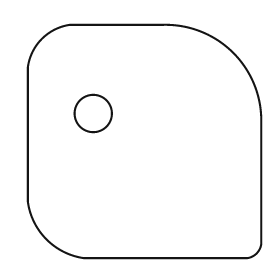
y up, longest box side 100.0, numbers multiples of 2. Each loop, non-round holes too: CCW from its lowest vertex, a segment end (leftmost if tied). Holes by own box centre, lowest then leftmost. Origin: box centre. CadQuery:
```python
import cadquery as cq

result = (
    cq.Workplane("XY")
    .moveTo(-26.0, -50.0)
    .lineTo(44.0, -50.0)
    .threePointArc((48.0, -48.0), (50.0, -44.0))
    .lineTo(50.0, 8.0)
    .threePointArc((38.0, 38.0), (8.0, 50.0))
    .lineTo(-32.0, 50.0)
    .threePointArc((-44.0, 44.0), (-50.0, 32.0))
    .lineTo(-50.0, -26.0)
    .threePointArc((-42.0, -42.0), (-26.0, -50.0))
    .close()
    .moveTo(-22.0, 12.0)
    .circle(8.0)
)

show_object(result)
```